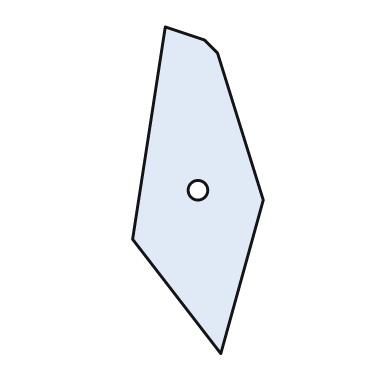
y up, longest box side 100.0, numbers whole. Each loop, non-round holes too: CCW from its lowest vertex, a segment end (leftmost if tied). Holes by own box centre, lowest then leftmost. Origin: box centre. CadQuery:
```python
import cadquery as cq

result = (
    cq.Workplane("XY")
    .moveTo(7.0, -50.0)
    .lineTo(20.0, -3.0)
    .lineTo(6.0, 42.0)
    .lineTo(2.0, 46.0)
    .lineTo(-10.0, 50.0)
    .lineTo(-20.0, -15.0)
    .close()
    .moveTo(0.0, 0.0)
    .circle(3.0)
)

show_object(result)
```